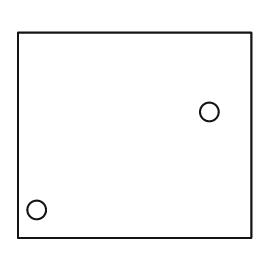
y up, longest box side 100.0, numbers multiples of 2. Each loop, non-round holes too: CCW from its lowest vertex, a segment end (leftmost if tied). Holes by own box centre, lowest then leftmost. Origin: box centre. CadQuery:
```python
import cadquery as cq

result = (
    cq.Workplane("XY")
    .moveTo(-50.0, -44.0)
    .lineTo(50.0, -44.0)
    .lineTo(50.0, 44.0)
    .lineTo(-50.0, 44.0)
    .close()
    .moveTo(-42.0, -32.0)
    .circle(4.0)
    .moveTo(32.0, 10.0)
    .circle(4.0)
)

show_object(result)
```